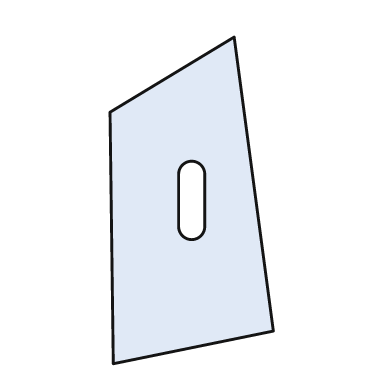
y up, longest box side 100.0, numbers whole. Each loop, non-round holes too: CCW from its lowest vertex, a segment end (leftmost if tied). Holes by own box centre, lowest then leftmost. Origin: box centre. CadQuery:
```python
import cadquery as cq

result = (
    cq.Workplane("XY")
    .moveTo(-24.0, -50.0)
    .lineTo(25.0, -40.0)
    .lineTo(13.0, 50.0)
    .lineTo(-25.0, 27.0)
    .close()
    .moveTo(-4.0, -8.0)
    .threePointArc((0.0, -12.0), (4.0, -8.0))
    .lineTo(4.0, 8.0)
    .threePointArc((0.0, 12.0), (-4.0, 8.0))
    .close()
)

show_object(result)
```